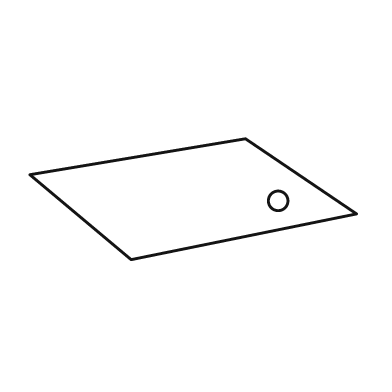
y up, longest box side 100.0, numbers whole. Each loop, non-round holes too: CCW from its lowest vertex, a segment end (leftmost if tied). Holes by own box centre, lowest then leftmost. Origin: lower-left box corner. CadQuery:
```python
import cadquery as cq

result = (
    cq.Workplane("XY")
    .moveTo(31.0, 0.0)
    .lineTo(100.0, 14.0)
    .lineTo(66.0, 37.0)
    .lineTo(0.0, 26.0)
    .close()
    .moveTo(76.0, 18.0)
    .circle(3.0)
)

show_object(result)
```